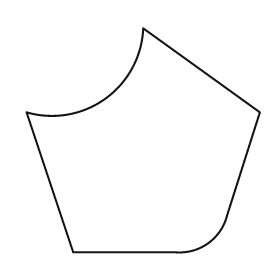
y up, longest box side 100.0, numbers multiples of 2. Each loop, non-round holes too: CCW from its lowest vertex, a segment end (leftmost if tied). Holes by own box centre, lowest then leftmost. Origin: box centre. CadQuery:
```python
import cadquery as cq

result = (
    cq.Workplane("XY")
    .moveTo(-30.0, -48.0)
    .lineTo(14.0, -48.0)
    .threePointArc((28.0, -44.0), (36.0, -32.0))
    .lineTo(50.0, 12.0)
    .lineTo(0.0, 48.0)
    .threePointArc((-16.0, 18.0), (-50.0, 12.0))
    .close()
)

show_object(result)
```